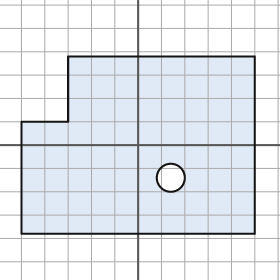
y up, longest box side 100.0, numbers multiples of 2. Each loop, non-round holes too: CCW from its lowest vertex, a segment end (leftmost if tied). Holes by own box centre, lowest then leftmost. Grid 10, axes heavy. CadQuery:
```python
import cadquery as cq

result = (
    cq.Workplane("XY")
    .moveTo(-50.0, -38.0)
    .lineTo(50.0, -38.0)
    .lineTo(50.0, 38.0)
    .lineTo(-30.0, 38.0)
    .lineTo(-30.0, 10.0)
    .lineTo(-50.0, 10.0)
    .close()
    .moveTo(14.0, -14.0)
    .circle(6.0)
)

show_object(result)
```